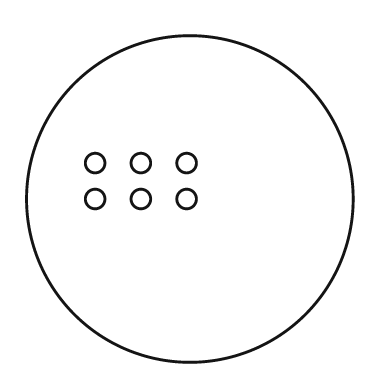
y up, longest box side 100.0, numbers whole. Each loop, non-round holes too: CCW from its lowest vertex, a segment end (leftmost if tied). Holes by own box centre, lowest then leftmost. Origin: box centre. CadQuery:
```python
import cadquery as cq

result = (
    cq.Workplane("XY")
    .moveTo(0.0, 0.0)
    .circle(50.0)
    .moveTo(-29.0, 0.0)
    .circle(3.0)
    .moveTo(-15.0, 0.0)
    .circle(3.0)
    .moveTo(-1.0, 0.0)
    .circle(3.0)
    .moveTo(-29.0, 11.0)
    .circle(3.0)
    .moveTo(-15.0, 11.0)
    .circle(3.0)
    .moveTo(-1.0, 11.0)
    .circle(3.0)
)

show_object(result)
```